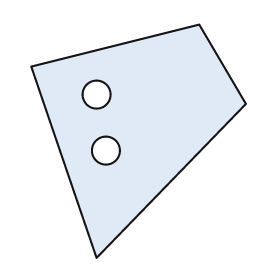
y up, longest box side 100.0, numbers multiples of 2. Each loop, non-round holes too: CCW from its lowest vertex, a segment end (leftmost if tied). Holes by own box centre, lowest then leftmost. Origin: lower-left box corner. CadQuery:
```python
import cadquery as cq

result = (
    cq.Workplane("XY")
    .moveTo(28.0, 0.0)
    .lineTo(92.0, 66.0)
    .lineTo(72.0, 100.0)
    .lineTo(0.0, 82.0)
    .close()
    .moveTo(32.0, 46.0)
    .circle(6.0)
    .moveTo(28.0, 70.0)
    .circle(6.0)
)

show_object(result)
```